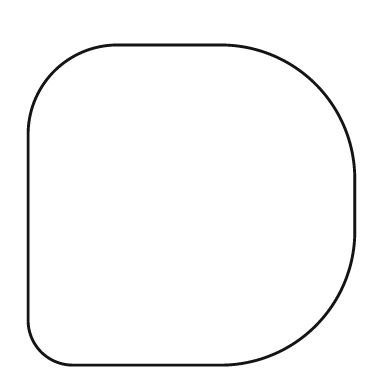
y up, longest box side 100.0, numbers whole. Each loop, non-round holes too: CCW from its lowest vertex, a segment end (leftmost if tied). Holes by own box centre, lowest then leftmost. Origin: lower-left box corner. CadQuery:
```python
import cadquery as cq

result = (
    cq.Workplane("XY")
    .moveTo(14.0, 0.0)
    .lineTo(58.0, 0.0)
    .threePointArc((88.0, 12.0), (100.0, 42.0))
    .lineTo(100.0, 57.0)
    .threePointArc((88.0, 86.0), (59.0, 98.0))
    .lineTo(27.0, 98.0)
    .threePointArc((8.0, 90.0), (0.0, 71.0))
    .lineTo(0.0, 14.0)
    .threePointArc((4.0, 4.0), (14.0, 0.0))
    .close()
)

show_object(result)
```